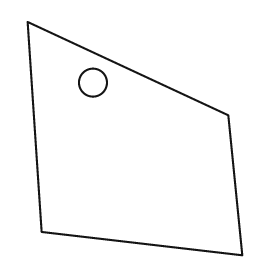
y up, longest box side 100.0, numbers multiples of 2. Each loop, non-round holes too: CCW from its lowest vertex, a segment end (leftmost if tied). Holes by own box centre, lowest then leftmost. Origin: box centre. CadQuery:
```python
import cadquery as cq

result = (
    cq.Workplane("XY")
    .moveTo(46.0, -50.0)
    .lineTo(40.0, 10.0)
    .lineTo(-46.0, 50.0)
    .lineTo(-40.0, -40.0)
    .close()
    .moveTo(-18.0, 24.0)
    .circle(6.0)
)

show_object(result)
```